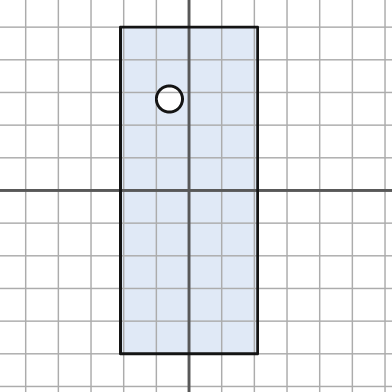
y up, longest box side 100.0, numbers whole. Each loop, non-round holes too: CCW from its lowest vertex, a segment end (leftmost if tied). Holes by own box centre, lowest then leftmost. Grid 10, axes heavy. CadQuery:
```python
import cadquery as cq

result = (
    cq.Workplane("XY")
    .moveTo(-21.0, -50.0)
    .lineTo(21.0, -50.0)
    .lineTo(21.0, 50.0)
    .lineTo(-21.0, 50.0)
    .close()
    .moveTo(-6.0, 28.0)
    .circle(4.0)
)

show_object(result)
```